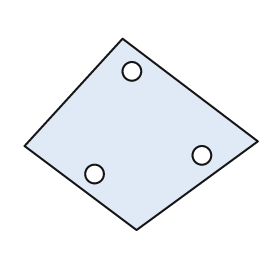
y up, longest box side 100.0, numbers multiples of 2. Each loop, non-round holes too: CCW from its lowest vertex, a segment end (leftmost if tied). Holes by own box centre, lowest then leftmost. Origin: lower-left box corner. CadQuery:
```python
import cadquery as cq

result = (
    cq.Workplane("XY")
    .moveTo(48.0, 0.0)
    .lineTo(100.0, 38.0)
    .lineTo(42.0, 82.0)
    .lineTo(0.0, 36.0)
    .close()
    .moveTo(30.0, 24.0)
    .circle(4.0)
    .moveTo(76.0, 32.0)
    .circle(4.0)
    .moveTo(46.0, 68.0)
    .circle(4.0)
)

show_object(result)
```